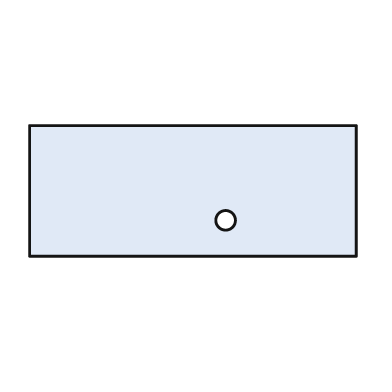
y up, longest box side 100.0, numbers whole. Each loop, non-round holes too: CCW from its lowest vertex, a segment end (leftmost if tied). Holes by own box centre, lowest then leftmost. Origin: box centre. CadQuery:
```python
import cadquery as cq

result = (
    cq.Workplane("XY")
    .moveTo(-50.0, -20.0)
    .lineTo(50.0, -20.0)
    .lineTo(50.0, 20.0)
    .lineTo(-50.0, 20.0)
    .close()
    .moveTo(10.0, -9.0)
    .circle(3.0)
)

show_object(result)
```